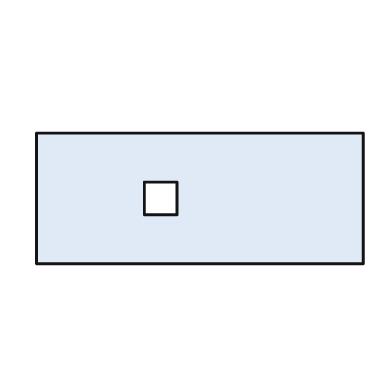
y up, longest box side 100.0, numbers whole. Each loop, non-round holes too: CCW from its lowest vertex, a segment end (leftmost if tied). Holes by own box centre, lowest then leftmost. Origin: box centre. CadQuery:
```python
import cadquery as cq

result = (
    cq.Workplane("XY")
    .moveTo(-50.0, -20.0)
    .lineTo(50.0, -20.0)
    .lineTo(50.0, 20.0)
    .lineTo(-50.0, 20.0)
    .close()
    .moveTo(-17.0, -5.0)
    .lineTo(-7.0, -5.0)
    .lineTo(-7.0, 5.0)
    .lineTo(-17.0, 5.0)
    .close()
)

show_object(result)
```